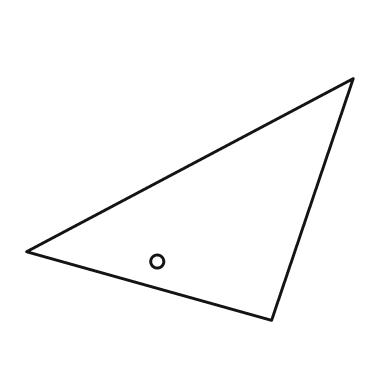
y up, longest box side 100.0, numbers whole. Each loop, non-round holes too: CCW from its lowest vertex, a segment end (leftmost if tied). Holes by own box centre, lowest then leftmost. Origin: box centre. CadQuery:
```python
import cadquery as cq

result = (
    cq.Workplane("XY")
    .moveTo(25.0, -37.0)
    .lineTo(50.0, 37.0)
    .lineTo(-50.0, -16.0)
    .close()
    .moveTo(-10.0, -19.0)
    .circle(2.0)
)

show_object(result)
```